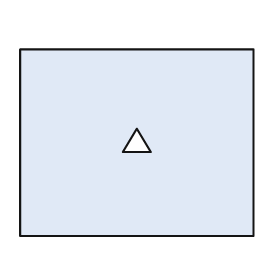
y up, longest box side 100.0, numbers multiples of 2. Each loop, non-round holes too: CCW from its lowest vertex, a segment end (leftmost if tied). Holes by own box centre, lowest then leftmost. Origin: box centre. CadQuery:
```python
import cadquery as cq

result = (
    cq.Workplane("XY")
    .moveTo(-50.0, -40.0)
    .lineTo(50.0, -40.0)
    .lineTo(50.0, 40.0)
    .lineTo(-50.0, 40.0)
    .close()
    .moveTo(-6.0, -4.0)
    .lineTo(6.0, -4.0)
    .lineTo(0.0, 6.0)
    .close()
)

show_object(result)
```